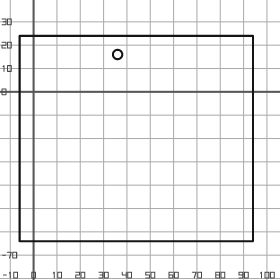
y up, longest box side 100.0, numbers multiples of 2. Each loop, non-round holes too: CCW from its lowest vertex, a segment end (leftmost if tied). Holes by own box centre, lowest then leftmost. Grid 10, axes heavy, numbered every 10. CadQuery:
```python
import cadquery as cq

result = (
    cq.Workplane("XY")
    .moveTo(-6.0, -64.0)
    .lineTo(94.0, -64.0)
    .lineTo(94.0, 24.0)
    .lineTo(-6.0, 24.0)
    .close()
    .moveTo(36.0, 16.0)
    .circle(2.0)
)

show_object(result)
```